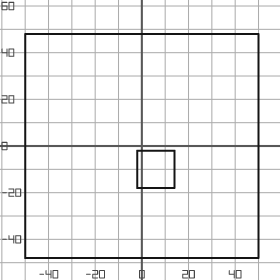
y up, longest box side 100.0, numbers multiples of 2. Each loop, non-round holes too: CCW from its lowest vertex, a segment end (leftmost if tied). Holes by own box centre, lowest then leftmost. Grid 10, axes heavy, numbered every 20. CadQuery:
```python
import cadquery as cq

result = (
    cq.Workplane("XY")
    .moveTo(-50.0, -48.0)
    .lineTo(50.0, -48.0)
    .lineTo(50.0, 48.0)
    .lineTo(-50.0, 48.0)
    .close()
    .moveTo(-2.0, -18.0)
    .lineTo(14.0, -18.0)
    .lineTo(14.0, -2.0)
    .lineTo(-2.0, -2.0)
    .close()
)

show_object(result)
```